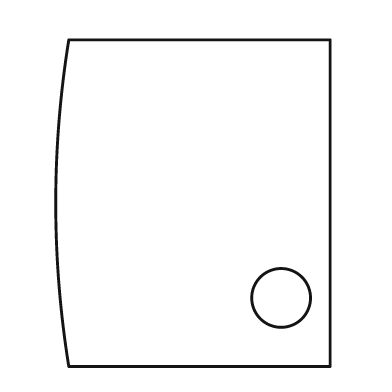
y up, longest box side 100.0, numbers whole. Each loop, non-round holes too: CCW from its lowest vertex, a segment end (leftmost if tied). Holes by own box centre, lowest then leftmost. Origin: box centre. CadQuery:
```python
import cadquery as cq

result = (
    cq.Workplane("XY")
    .moveTo(-38.0, -50.0)
    .lineTo(42.0, -50.0)
    .lineTo(42.0, 50.0)
    .lineTo(-38.0, 50.0)
    .threePointArc((-42.0, 0.0), (-38.0, -50.0))
    .close()
    .moveTo(27.0, -29.0)
    .circle(9.0)
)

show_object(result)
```